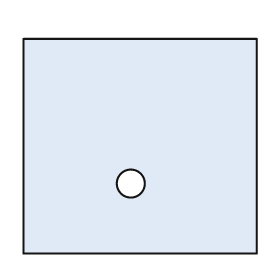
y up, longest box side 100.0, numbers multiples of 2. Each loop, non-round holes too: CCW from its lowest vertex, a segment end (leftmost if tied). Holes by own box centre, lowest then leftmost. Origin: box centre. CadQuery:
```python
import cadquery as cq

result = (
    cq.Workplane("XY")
    .moveTo(-50.0, -46.0)
    .lineTo(50.0, -46.0)
    .lineTo(50.0, 46.0)
    .lineTo(-50.0, 46.0)
    .close()
    .moveTo(-4.0, -16.0)
    .circle(6.0)
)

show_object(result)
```